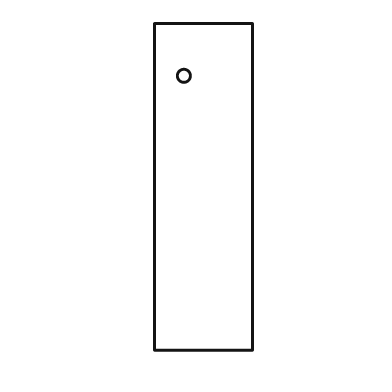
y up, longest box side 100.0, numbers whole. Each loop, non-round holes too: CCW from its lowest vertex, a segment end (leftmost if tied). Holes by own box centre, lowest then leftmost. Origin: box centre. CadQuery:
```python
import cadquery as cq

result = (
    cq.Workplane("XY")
    .moveTo(-15.0, -50.0)
    .lineTo(15.0, -50.0)
    .lineTo(15.0, 50.0)
    .lineTo(-15.0, 50.0)
    .close()
    .moveTo(-6.0, 34.0)
    .circle(2.0)
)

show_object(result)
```